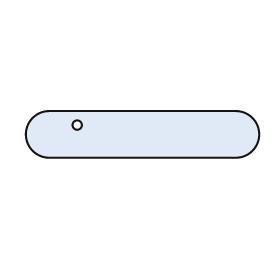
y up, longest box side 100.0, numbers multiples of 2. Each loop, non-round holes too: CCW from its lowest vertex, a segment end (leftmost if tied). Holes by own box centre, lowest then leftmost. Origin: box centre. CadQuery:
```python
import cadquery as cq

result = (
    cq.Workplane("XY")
    .moveTo(-40.0, -10.0)
    .lineTo(40.0, -10.0)
    .threePointArc((50.0, 0.0), (40.0, 10.0))
    .lineTo(-40.0, 10.0)
    .threePointArc((-50.0, 0.0), (-40.0, -10.0))
    .close()
    .moveTo(-28.0, 4.0)
    .circle(2.0)
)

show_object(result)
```